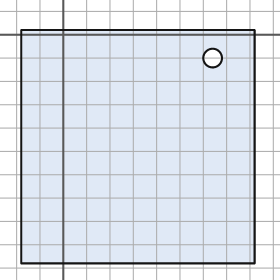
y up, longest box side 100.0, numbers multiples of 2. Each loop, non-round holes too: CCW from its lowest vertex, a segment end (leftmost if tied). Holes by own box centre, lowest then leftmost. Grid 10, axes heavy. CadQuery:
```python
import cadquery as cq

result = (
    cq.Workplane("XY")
    .moveTo(-18.0, -98.0)
    .lineTo(82.0, -98.0)
    .lineTo(82.0, 2.0)
    .lineTo(-18.0, 2.0)
    .close()
    .moveTo(64.0, -10.0)
    .circle(4.0)
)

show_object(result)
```